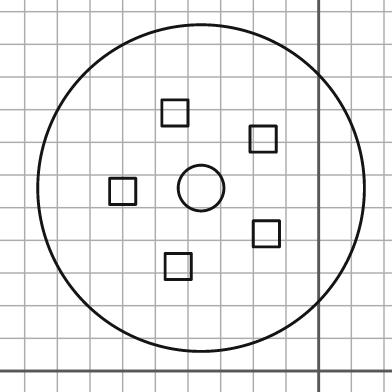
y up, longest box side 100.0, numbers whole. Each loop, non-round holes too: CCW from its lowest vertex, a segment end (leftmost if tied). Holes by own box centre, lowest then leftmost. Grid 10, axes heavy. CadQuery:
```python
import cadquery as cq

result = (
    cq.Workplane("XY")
    .moveTo(-36.0, 56.0)
    .circle(50.0)
    .moveTo(-47.0, 28.0)
    .lineTo(-39.0, 28.0)
    .lineTo(-39.0, 36.0)
    .lineTo(-47.0, 36.0)
    .close()
    .moveTo(-20.0, 38.0)
    .lineTo(-12.0, 38.0)
    .lineTo(-12.0, 46.0)
    .lineTo(-20.0, 46.0)
    .close()
    .moveTo(-64.0, 51.0)
    .lineTo(-56.0, 51.0)
    .lineTo(-56.0, 59.0)
    .lineTo(-64.0, 59.0)
    .close()
    .moveTo(-36.0, 56.0)
    .circle(7.0)
    .moveTo(-21.0, 67.0)
    .lineTo(-13.0, 67.0)
    .lineTo(-13.0, 75.0)
    .lineTo(-21.0, 75.0)
    .close()
    .moveTo(-48.0, 75.0)
    .lineTo(-40.0, 75.0)
    .lineTo(-40.0, 83.0)
    .lineTo(-48.0, 83.0)
    .close()
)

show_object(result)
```